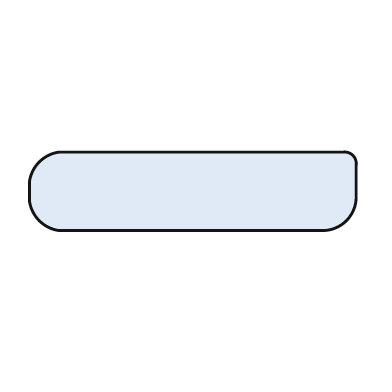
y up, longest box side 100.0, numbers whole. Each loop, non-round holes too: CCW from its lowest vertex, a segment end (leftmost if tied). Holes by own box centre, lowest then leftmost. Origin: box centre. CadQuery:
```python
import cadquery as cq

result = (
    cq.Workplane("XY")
    .moveTo(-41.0, -12.0)
    .lineTo(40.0, -12.0)
    .threePointArc((47.0, -9.0), (50.0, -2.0))
    .lineTo(50.0, 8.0)
    .threePointArc((49.0, 11.0), (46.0, 12.0))
    .lineTo(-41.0, 12.0)
    .threePointArc((-47.0, 9.0), (-50.0, 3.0))
    .lineTo(-50.0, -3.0)
    .threePointArc((-47.0, -9.0), (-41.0, -12.0))
    .close()
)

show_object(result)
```